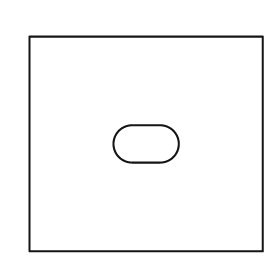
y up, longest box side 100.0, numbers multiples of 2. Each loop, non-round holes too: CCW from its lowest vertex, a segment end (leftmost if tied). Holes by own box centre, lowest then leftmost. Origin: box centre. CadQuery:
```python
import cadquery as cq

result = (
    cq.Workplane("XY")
    .moveTo(-50.0, -46.0)
    .lineTo(50.0, -46.0)
    .lineTo(50.0, 46.0)
    .lineTo(-50.0, 46.0)
    .close()
    .moveTo(-6.0, -8.0)
    .lineTo(6.0, -8.0)
    .threePointArc((14.0, 0.0), (6.0, 8.0))
    .lineTo(-6.0, 8.0)
    .threePointArc((-14.0, 0.0), (-6.0, -8.0))
    .close()
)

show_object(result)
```